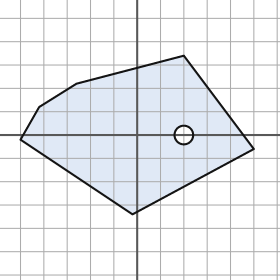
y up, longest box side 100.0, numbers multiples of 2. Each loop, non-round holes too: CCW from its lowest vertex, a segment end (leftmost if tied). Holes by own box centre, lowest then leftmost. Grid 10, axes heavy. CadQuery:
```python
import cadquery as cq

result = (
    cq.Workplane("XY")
    .moveTo(-2.0, -34.0)
    .lineTo(50.0, -6.0)
    .lineTo(20.0, 34.0)
    .lineTo(-26.0, 22.0)
    .lineTo(-42.0, 12.0)
    .lineTo(-50.0, -2.0)
    .close()
    .moveTo(20.0, 0.0)
    .circle(4.0)
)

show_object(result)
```